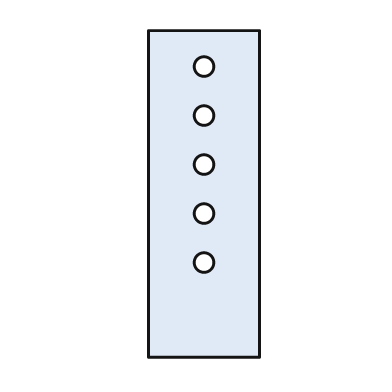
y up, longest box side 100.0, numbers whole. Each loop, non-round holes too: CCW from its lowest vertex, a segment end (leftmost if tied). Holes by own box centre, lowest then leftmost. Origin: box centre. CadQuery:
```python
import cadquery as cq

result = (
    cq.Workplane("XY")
    .moveTo(-17.0, -50.0)
    .lineTo(17.0, -50.0)
    .lineTo(17.0, 50.0)
    .lineTo(-17.0, 50.0)
    .close()
    .moveTo(0.0, -21.0)
    .circle(3.0)
    .moveTo(0.0, -6.0)
    .circle(3.0)
    .moveTo(0.0, 9.0)
    .circle(3.0)
    .moveTo(0.0, 24.0)
    .circle(3.0)
    .moveTo(0.0, 39.0)
    .circle(3.0)
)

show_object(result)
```